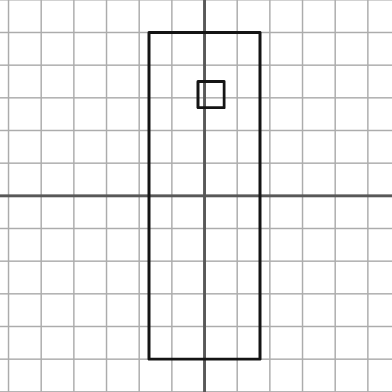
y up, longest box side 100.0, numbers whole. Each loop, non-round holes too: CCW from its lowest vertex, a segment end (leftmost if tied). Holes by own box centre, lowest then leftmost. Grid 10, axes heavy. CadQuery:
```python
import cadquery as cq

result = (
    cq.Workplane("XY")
    .moveTo(-17.0, -50.0)
    .lineTo(17.0, -50.0)
    .lineTo(17.0, 50.0)
    .lineTo(-17.0, 50.0)
    .close()
    .moveTo(-2.0, 27.0)
    .lineTo(6.0, 27.0)
    .lineTo(6.0, 35.0)
    .lineTo(-2.0, 35.0)
    .close()
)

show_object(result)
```